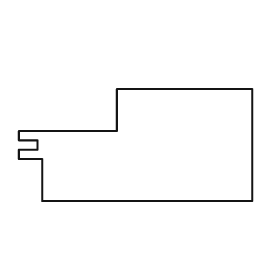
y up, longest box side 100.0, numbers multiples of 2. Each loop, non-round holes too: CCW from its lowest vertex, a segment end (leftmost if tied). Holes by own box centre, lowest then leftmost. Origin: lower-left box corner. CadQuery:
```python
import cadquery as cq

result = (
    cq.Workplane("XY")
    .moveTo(10.0, 0.0)
    .lineTo(100.0, 0.0)
    .lineTo(100.0, 48.0)
    .lineTo(42.0, 48.0)
    .lineTo(42.0, 30.0)
    .lineTo(0.0, 30.0)
    .lineTo(0.0, 26.0)
    .lineTo(8.0, 26.0)
    .lineTo(8.0, 22.0)
    .lineTo(0.0, 22.0)
    .lineTo(0.0, 18.0)
    .lineTo(10.0, 18.0)
    .close()
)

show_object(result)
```